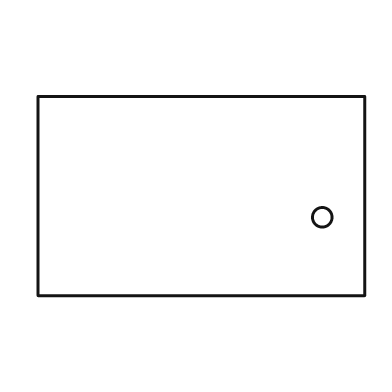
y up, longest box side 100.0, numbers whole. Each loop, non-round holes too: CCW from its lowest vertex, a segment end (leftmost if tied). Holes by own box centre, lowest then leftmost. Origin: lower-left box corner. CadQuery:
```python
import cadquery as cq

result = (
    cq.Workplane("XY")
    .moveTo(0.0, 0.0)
    .lineTo(100.0, 0.0)
    .lineTo(100.0, 61.0)
    .lineTo(0.0, 61.0)
    .close()
    .moveTo(87.0, 24.0)
    .circle(3.0)
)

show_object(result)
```